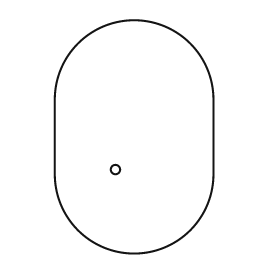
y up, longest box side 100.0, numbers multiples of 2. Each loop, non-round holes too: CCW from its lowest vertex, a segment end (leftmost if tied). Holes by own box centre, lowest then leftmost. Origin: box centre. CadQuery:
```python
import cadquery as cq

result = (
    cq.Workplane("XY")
    .moveTo(-34.0, -16.0)
    .threePointArc((0.0, -50.0), (34.0, -16.0))
    .lineTo(34.0, 16.0)
    .threePointArc((0.0, 50.0), (-34.0, 16.0))
    .close()
    .moveTo(-8.0, -14.0)
    .circle(2.0)
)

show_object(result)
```